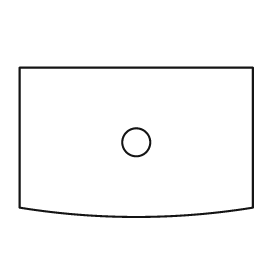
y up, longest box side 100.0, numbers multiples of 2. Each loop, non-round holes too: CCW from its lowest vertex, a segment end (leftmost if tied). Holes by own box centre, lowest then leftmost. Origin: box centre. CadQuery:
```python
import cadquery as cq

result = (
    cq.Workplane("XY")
    .moveTo(-50.0, -28.0)
    .threePointArc((0.0, -32.0), (50.0, -28.0))
    .lineTo(50.0, 32.0)
    .lineTo(-50.0, 32.0)
    .close()
    .moveTo(0.0, 0.0)
    .circle(6.0)
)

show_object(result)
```